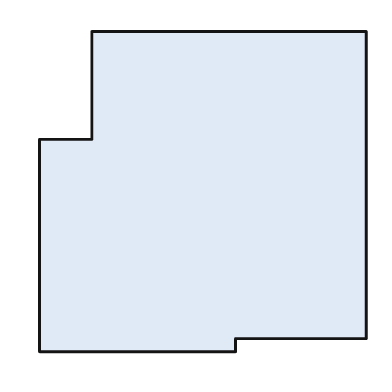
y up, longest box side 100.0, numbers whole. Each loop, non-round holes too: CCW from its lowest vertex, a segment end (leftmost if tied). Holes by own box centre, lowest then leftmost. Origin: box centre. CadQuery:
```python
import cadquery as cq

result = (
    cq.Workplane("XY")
    .moveTo(-50.0, -49.0)
    .lineTo(10.0, -49.0)
    .lineTo(10.0, -45.0)
    .lineTo(50.0, -45.0)
    .lineTo(50.0, 49.0)
    .lineTo(-34.0, 49.0)
    .lineTo(-34.0, 16.0)
    .lineTo(-50.0, 16.0)
    .close()
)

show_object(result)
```